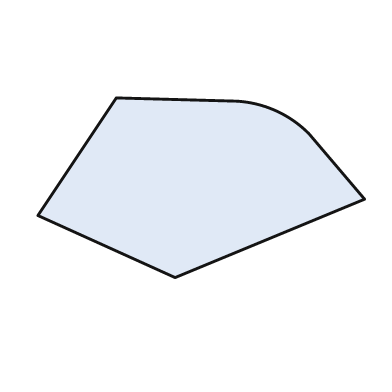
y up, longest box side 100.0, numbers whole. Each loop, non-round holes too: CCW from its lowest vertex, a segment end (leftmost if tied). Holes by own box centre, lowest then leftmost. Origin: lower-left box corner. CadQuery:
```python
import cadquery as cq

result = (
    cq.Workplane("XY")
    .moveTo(42.0, 0.0)
    .lineTo(100.0, 24.0)
    .lineTo(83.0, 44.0)
    .threePointArc((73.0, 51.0), (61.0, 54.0))
    .lineTo(24.0, 55.0)
    .lineTo(0.0, 19.0)
    .close()
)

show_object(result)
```